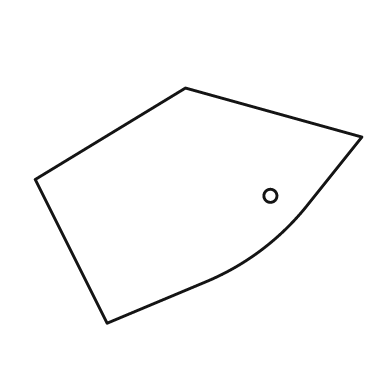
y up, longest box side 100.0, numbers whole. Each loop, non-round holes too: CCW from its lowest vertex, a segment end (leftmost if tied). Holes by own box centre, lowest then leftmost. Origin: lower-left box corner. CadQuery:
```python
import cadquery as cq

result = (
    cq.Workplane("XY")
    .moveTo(22.0, 0.0)
    .lineTo(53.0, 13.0)
    .threePointArc((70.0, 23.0), (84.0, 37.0))
    .lineTo(100.0, 57.0)
    .lineTo(46.0, 72.0)
    .lineTo(0.0, 44.0)
    .close()
    .moveTo(72.0, 39.0)
    .circle(2.0)
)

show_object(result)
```